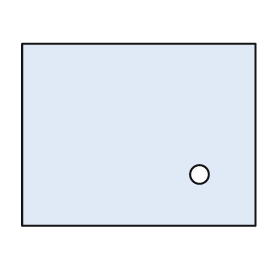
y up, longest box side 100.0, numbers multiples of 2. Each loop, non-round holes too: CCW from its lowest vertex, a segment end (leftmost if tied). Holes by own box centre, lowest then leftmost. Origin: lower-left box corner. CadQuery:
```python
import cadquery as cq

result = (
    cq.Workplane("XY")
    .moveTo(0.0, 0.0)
    .lineTo(100.0, 0.0)
    .lineTo(100.0, 78.0)
    .lineTo(0.0, 78.0)
    .close()
    .moveTo(76.0, 22.0)
    .circle(4.0)
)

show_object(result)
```